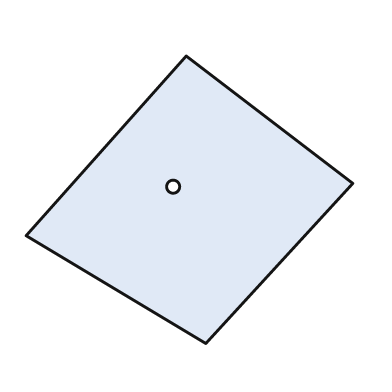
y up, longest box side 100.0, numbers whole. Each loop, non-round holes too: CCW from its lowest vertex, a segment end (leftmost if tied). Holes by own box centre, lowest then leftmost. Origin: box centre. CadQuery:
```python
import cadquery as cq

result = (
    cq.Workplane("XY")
    .moveTo(5.0, -44.0)
    .lineTo(50.0, 5.0)
    .lineTo(-1.0, 44.0)
    .lineTo(-50.0, -11.0)
    .close()
    .moveTo(-5.0, 4.0)
    .circle(2.0)
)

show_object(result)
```